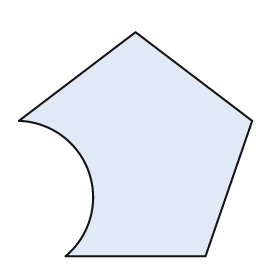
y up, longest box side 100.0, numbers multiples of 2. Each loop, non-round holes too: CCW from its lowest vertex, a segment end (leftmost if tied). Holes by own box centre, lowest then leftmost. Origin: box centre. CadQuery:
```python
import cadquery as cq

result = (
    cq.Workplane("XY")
    .moveTo(-30.0, -48.0)
    .lineTo(30.0, -48.0)
    .lineTo(50.0, 10.0)
    .lineTo(0.0, 48.0)
    .lineTo(-50.0, 10.0)
    .threePointArc((-20.0, -12.0), (-30.0, -48.0))
    .close()
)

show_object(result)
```